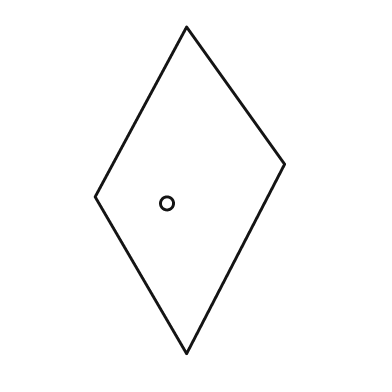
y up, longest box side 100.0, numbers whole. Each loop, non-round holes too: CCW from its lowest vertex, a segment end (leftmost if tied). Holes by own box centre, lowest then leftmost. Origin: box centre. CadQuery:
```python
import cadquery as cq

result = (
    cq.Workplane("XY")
    .moveTo(-1.0, -50.0)
    .lineTo(29.0, 8.0)
    .lineTo(-1.0, 50.0)
    .lineTo(-29.0, -2.0)
    .close()
    .moveTo(-7.0, -4.0)
    .circle(2.0)
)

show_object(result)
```